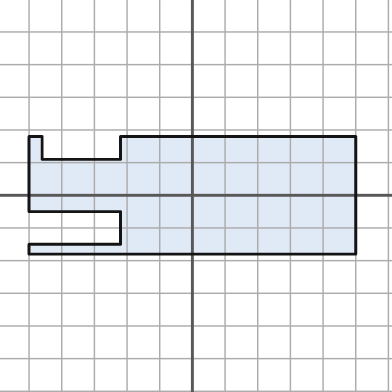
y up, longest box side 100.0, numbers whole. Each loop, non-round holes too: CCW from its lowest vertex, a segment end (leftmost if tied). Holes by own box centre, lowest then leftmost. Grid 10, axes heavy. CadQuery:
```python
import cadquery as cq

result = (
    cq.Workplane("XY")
    .moveTo(-50.0, -18.0)
    .lineTo(50.0, -18.0)
    .lineTo(50.0, 18.0)
    .lineTo(-22.0, 18.0)
    .lineTo(-22.0, 11.0)
    .lineTo(-46.0, 11.0)
    .lineTo(-46.0, 18.0)
    .lineTo(-50.0, 18.0)
    .lineTo(-50.0, -5.0)
    .lineTo(-22.0, -5.0)
    .lineTo(-22.0, -15.0)
    .lineTo(-50.0, -15.0)
    .close()
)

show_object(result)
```